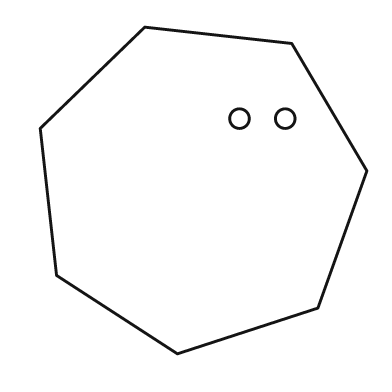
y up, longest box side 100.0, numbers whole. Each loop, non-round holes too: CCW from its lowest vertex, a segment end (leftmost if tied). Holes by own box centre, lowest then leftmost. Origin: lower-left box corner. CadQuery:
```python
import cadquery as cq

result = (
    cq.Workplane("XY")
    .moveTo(42.0, 0.0)
    .lineTo(85.0, 14.0)
    .lineTo(100.0, 56.0)
    .lineTo(77.0, 95.0)
    .lineTo(32.0, 100.0)
    .lineTo(0.0, 69.0)
    .lineTo(5.0, 24.0)
    .close()
    .moveTo(61.0, 72.0)
    .circle(3.0)
    .moveTo(75.0, 72.0)
    .circle(3.0)
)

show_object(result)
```